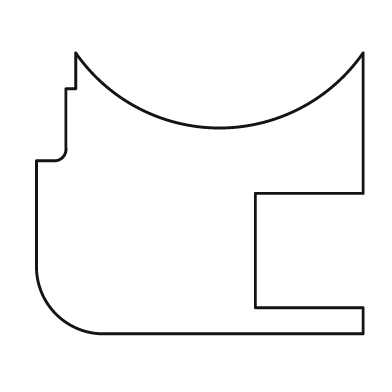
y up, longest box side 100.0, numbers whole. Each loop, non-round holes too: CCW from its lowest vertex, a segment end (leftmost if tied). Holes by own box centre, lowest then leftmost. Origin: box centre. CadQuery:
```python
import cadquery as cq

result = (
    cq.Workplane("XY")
    .moveTo(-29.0, -43.0)
    .lineTo(50.0, -43.0)
    .lineTo(50.0, -35.0)
    .lineTo(17.0, -35.0)
    .lineTo(17.0, 0.0)
    .lineTo(50.0, 0.0)
    .lineTo(50.0, 43.0)
    .threePointArc((6.0, 20.0), (-38.0, 43.0))
    .lineTo(-38.0, 32.0)
    .lineTo(-41.0, 32.0)
    .lineTo(-41.0, 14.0)
    .threePointArc((-42.0, 11.0), (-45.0, 10.0))
    .lineTo(-50.0, 10.0)
    .lineTo(-50.0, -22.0)
    .threePointArc((-44.0, -37.0), (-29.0, -43.0))
    .close()
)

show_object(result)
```